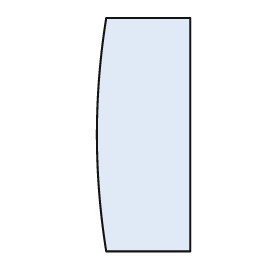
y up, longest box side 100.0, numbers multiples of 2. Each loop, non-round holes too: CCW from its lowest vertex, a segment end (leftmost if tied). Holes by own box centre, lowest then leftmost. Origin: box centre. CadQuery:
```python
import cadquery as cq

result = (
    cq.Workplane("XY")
    .moveTo(-16.0, -50.0)
    .lineTo(20.0, -50.0)
    .lineTo(20.0, 50.0)
    .lineTo(-16.0, 50.0)
    .threePointArc((-20.0, 0.0), (-16.0, -50.0))
    .close()
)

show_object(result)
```